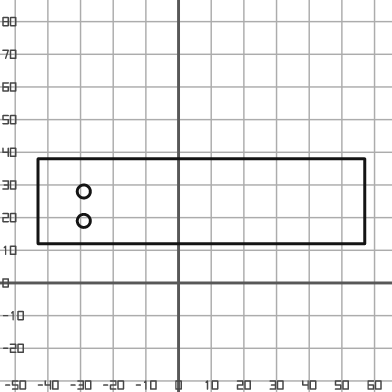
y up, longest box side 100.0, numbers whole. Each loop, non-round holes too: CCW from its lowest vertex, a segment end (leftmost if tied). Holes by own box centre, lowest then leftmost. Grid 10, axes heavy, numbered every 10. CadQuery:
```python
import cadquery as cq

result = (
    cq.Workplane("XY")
    .moveTo(-43.0, 12.0)
    .lineTo(57.0, 12.0)
    .lineTo(57.0, 38.0)
    .lineTo(-43.0, 38.0)
    .close()
    .moveTo(-29.0, 19.0)
    .circle(2.0)
    .moveTo(-29.0, 28.0)
    .circle(2.0)
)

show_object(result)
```